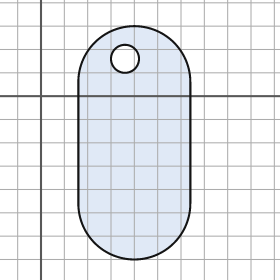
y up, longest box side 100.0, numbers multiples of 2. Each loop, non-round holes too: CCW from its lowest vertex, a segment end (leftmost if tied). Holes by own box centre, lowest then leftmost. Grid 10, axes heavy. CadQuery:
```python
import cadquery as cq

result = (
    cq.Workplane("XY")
    .moveTo(16.0, -46.0)
    .threePointArc((40.0, -70.0), (64.0, -46.0))
    .lineTo(64.0, 6.0)
    .threePointArc((40.0, 30.0), (16.0, 6.0))
    .close()
    .moveTo(36.0, 16.0)
    .circle(6.0)
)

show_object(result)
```